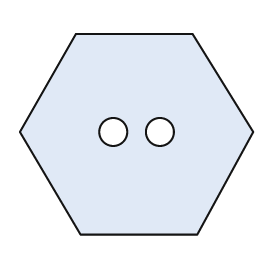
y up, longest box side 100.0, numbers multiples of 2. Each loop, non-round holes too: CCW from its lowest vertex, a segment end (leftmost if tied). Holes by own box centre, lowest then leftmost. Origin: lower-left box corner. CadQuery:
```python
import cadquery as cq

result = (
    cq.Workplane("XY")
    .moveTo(26.0, 0.0)
    .lineTo(76.0, 0.0)
    .lineTo(100.0, 44.0)
    .lineTo(74.0, 86.0)
    .lineTo(24.0, 86.0)
    .lineTo(0.0, 44.0)
    .close()
    .moveTo(40.0, 44.0)
    .circle(6.0)
    .moveTo(60.0, 44.0)
    .circle(6.0)
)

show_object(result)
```